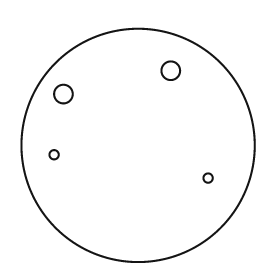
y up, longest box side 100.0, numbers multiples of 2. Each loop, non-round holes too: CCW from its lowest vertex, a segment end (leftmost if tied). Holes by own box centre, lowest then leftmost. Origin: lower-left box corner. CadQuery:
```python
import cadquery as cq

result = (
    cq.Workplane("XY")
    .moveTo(50.0, 50.0)
    .circle(50.0)
    .moveTo(80.0, 36.0)
    .circle(2.0)
    .moveTo(14.0, 46.0)
    .circle(2.0)
    .moveTo(18.0, 72.0)
    .circle(4.0)
    .moveTo(64.0, 82.0)
    .circle(4.0)
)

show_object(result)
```